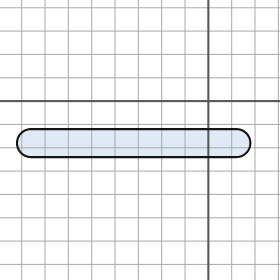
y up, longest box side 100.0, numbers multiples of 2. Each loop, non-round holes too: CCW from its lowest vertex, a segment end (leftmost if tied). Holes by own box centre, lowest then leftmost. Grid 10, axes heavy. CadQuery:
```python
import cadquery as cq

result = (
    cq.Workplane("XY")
    .moveTo(-76.0, -24.0)
    .lineTo(12.0, -24.0)
    .threePointArc((18.0, -18.0), (12.0, -12.0))
    .lineTo(-76.0, -12.0)
    .threePointArc((-82.0, -18.0), (-76.0, -24.0))
    .close()
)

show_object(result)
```